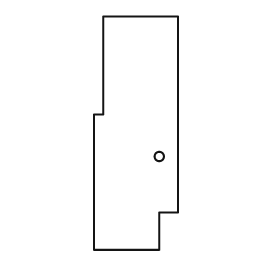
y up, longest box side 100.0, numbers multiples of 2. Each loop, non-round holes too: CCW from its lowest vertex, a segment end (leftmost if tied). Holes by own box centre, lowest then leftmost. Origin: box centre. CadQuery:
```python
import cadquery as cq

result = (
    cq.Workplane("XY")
    .moveTo(-18.0, -50.0)
    .lineTo(10.0, -50.0)
    .lineTo(10.0, -34.0)
    .lineTo(18.0, -34.0)
    .lineTo(18.0, 50.0)
    .lineTo(-14.0, 50.0)
    .lineTo(-14.0, 8.0)
    .lineTo(-18.0, 8.0)
    .close()
    .moveTo(10.0, -10.0)
    .circle(2.0)
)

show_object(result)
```